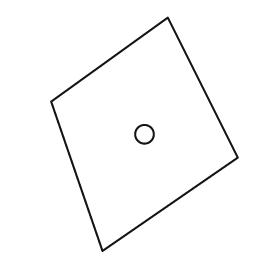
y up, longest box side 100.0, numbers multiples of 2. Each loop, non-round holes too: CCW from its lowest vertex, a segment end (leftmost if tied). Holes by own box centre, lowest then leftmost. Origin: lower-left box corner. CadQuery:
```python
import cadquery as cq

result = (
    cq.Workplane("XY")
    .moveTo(22.0, 0.0)
    .lineTo(80.0, 40.0)
    .lineTo(50.0, 100.0)
    .lineTo(0.0, 64.0)
    .close()
    .moveTo(40.0, 50.0)
    .circle(4.0)
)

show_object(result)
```